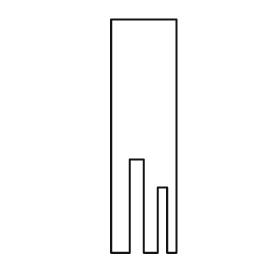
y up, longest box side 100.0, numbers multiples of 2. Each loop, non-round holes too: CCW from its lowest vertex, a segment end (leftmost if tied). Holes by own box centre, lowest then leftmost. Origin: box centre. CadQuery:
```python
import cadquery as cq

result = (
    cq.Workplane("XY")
    .moveTo(-14.0, -50.0)
    .lineTo(-6.0, -50.0)
    .lineTo(-6.0, -10.0)
    .lineTo(0.0, -10.0)
    .lineTo(0.0, -50.0)
    .lineTo(6.0, -50.0)
    .lineTo(6.0, -22.0)
    .lineTo(10.0, -22.0)
    .lineTo(10.0, -50.0)
    .lineTo(14.0, -50.0)
    .lineTo(14.0, 50.0)
    .lineTo(-14.0, 50.0)
    .close()
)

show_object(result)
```